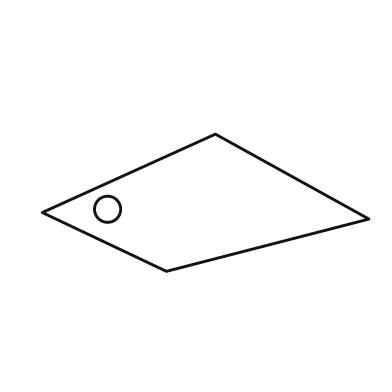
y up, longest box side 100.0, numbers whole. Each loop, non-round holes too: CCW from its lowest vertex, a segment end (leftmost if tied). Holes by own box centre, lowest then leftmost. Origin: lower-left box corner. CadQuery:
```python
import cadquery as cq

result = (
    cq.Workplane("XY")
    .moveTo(38.0, 0.0)
    .lineTo(100.0, 16.0)
    .lineTo(53.0, 42.0)
    .lineTo(0.0, 18.0)
    .close()
    .moveTo(20.0, 19.0)
    .circle(4.0)
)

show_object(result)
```